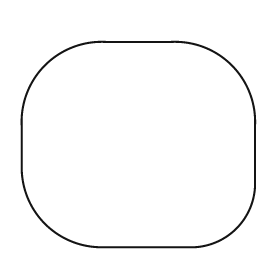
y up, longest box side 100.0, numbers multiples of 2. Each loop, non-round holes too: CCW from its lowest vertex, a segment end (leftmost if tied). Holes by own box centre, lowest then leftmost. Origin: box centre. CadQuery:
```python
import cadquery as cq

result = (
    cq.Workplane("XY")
    .moveTo(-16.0, -44.0)
    .lineTo(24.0, -44.0)
    .threePointArc((42.0, -36.0), (50.0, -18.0))
    .lineTo(50.0, 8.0)
    .threePointArc((40.0, 34.0), (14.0, 44.0))
    .lineTo(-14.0, 44.0)
    .threePointArc((-40.0, 34.0), (-50.0, 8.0))
    .lineTo(-50.0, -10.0)
    .threePointArc((-40.0, -34.0), (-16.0, -44.0))
    .close()
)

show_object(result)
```